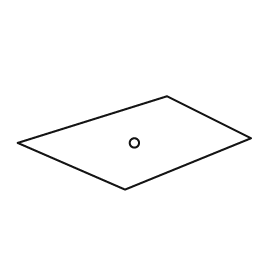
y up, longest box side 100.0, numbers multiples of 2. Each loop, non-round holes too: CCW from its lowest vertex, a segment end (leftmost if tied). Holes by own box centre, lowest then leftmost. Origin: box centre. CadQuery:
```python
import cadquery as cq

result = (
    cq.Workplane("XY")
    .moveTo(-4.0, -20.0)
    .lineTo(50.0, 2.0)
    .lineTo(14.0, 20.0)
    .lineTo(-50.0, 0.0)
    .close()
    .moveTo(0.0, 0.0)
    .circle(2.0)
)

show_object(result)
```